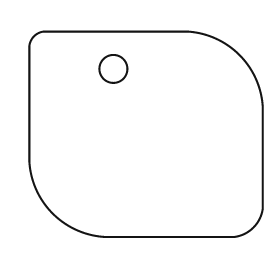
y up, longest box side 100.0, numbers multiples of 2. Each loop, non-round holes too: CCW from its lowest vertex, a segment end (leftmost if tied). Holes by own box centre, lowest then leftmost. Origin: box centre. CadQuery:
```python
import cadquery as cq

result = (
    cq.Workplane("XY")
    .moveTo(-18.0, -44.0)
    .lineTo(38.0, -44.0)
    .threePointArc((46.0, -40.0), (50.0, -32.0))
    .lineTo(50.0, 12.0)
    .threePointArc((40.0, 34.0), (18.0, 44.0))
    .lineTo(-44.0, 44.0)
    .threePointArc((-48.0, 42.0), (-50.0, 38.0))
    .lineTo(-50.0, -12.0)
    .threePointArc((-40.0, -34.0), (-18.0, -44.0))
    .close()
    .moveTo(-14.0, 28.0)
    .circle(6.0)
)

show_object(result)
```